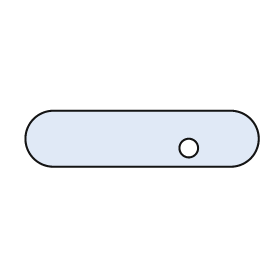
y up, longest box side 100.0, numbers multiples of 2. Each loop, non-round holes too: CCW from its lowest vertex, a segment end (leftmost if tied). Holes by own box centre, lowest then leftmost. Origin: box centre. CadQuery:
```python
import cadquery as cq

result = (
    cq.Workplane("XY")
    .moveTo(-38.0, -12.0)
    .lineTo(38.0, -12.0)
    .threePointArc((50.0, 0.0), (38.0, 12.0))
    .lineTo(-38.0, 12.0)
    .threePointArc((-50.0, 0.0), (-38.0, -12.0))
    .close()
    .moveTo(20.0, -4.0)
    .circle(4.0)
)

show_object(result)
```